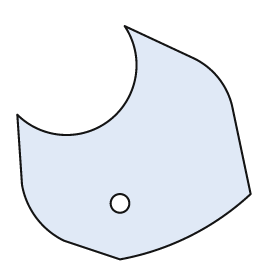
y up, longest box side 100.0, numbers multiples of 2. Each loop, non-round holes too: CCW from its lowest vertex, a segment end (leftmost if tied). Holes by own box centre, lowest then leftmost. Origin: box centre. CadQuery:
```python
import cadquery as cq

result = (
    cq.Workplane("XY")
    .moveTo(-6.0, -50.0)
    .threePointArc((24.0, -40.0), (50.0, -22.0))
    .lineTo(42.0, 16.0)
    .threePointArc((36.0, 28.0), (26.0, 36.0))
    .lineTo(-4.0, 50.0)
    .threePointArc((-10.0, 10.0), (-50.0, 12.0))
    .lineTo(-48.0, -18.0)
    .threePointArc((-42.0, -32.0), (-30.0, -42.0))
    .close()
    .moveTo(-6.0, -26.0)
    .circle(4.0)
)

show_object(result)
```